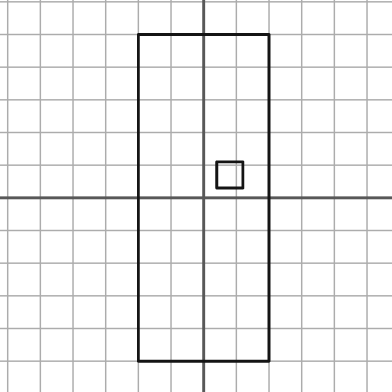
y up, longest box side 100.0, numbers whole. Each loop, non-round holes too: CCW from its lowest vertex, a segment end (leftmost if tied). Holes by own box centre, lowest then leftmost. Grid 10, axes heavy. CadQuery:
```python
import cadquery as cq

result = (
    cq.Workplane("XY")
    .moveTo(-20.0, -50.0)
    .lineTo(20.0, -50.0)
    .lineTo(20.0, 50.0)
    .lineTo(-20.0, 50.0)
    .close()
    .moveTo(4.0, 3.0)
    .lineTo(12.0, 3.0)
    .lineTo(12.0, 11.0)
    .lineTo(4.0, 11.0)
    .close()
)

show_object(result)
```